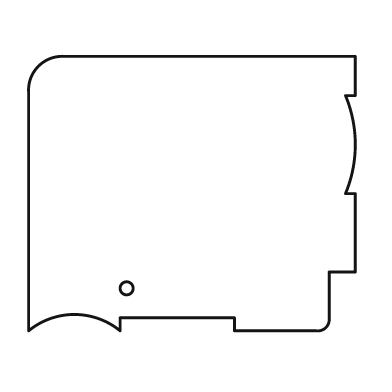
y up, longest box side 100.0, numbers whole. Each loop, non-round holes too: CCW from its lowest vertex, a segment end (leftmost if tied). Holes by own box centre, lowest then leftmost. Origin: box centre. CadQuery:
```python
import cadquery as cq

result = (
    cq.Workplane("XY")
    .moveTo(-50.0, -42.0)
    .threePointArc((-36.0, -37.0), (-22.0, -42.0))
    .lineTo(-22.0, -38.0)
    .lineTo(13.0, -38.0)
    .lineTo(13.0, -42.0)
    .lineTo(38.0, -42.0)
    .threePointArc((41.0, -41.0), (42.0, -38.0))
    .lineTo(42.0, -24.0)
    .lineTo(50.0, -24.0)
    .lineTo(50.0, 0.0)
    .lineTo(47.0, 0.0)
    .threePointArc((50.0, 15.0), (47.0, 30.0))
    .lineTo(50.0, 30.0)
    .lineTo(50.0, 42.0)
    .lineTo(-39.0, 42.0)
    .threePointArc((-47.0, 39.0), (-50.0, 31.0))
    .close()
    .moveTo(-20.0, -29.0)
    .circle(2.0)
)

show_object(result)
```